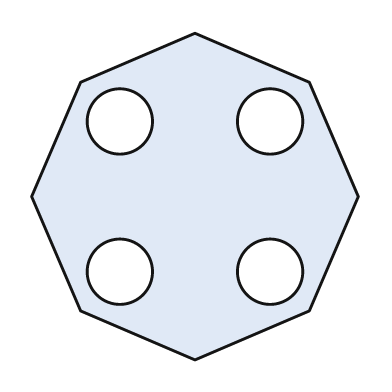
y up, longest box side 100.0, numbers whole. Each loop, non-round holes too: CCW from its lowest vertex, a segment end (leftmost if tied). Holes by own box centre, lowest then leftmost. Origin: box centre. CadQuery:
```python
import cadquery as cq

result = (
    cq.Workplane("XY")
    .moveTo(0.0, -50.0)
    .lineTo(35.0, -35.0)
    .lineTo(50.0, 0.0)
    .lineTo(35.0, 35.0)
    .lineTo(0.0, 50.0)
    .lineTo(-35.0, 35.0)
    .lineTo(-50.0, 0.0)
    .lineTo(-35.0, -35.0)
    .close()
    .moveTo(-23.0, -23.0)
    .circle(10.0)
    .moveTo(23.0, -23.0)
    .circle(10.0)
    .moveTo(-23.0, 23.0)
    .circle(10.0)
    .moveTo(23.0, 23.0)
    .circle(10.0)
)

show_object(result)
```